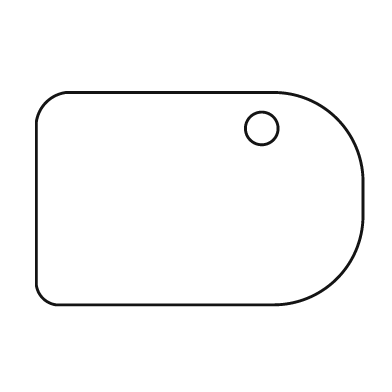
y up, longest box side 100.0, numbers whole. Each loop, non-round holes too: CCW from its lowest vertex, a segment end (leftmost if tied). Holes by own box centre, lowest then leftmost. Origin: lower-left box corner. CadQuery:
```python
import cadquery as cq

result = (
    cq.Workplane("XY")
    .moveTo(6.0, 0.0)
    .lineTo(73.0, 0.0)
    .threePointArc((92.0, 8.0), (100.0, 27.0))
    .lineTo(100.0, 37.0)
    .threePointArc((92.0, 57.0), (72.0, 65.0))
    .lineTo(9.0, 65.0)
    .threePointArc((3.0, 62.0), (0.0, 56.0))
    .lineTo(0.0, 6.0)
    .threePointArc((2.0, 2.0), (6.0, 0.0))
    .close()
    .moveTo(69.0, 54.0)
    .circle(5.0)
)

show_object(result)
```